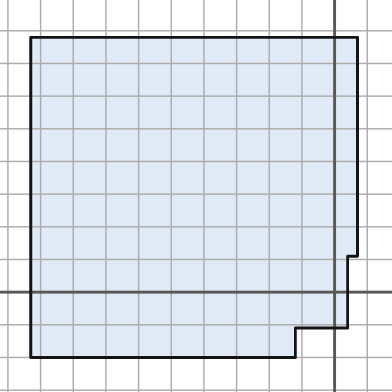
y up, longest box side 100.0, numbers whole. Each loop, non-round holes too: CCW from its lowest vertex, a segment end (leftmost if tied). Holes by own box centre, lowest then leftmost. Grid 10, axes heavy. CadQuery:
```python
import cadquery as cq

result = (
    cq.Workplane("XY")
    .moveTo(-93.0, -20.0)
    .lineTo(-12.0, -20.0)
    .lineTo(-12.0, -11.0)
    .lineTo(4.0, -11.0)
    .lineTo(4.0, 11.0)
    .lineTo(7.0, 11.0)
    .lineTo(7.0, 78.0)
    .lineTo(-93.0, 78.0)
    .close()
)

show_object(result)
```